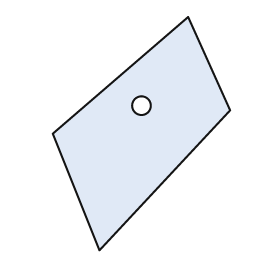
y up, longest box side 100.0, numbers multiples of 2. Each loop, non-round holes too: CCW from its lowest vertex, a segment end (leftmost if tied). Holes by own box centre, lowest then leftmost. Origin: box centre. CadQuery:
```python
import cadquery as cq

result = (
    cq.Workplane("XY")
    .moveTo(-18.0, -50.0)
    .lineTo(38.0, 10.0)
    .lineTo(20.0, 50.0)
    .lineTo(-38.0, 0.0)
    .close()
    .moveTo(0.0, 12.0)
    .circle(4.0)
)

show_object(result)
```